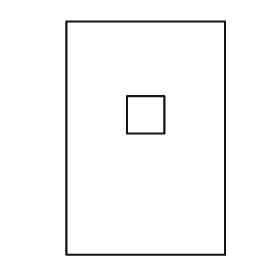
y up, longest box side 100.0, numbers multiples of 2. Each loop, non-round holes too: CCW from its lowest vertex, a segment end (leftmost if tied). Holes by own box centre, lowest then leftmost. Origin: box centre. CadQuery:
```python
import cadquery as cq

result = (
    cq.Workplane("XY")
    .moveTo(-34.0, -50.0)
    .lineTo(34.0, -50.0)
    .lineTo(34.0, 50.0)
    .lineTo(-34.0, 50.0)
    .close()
    .moveTo(-8.0, 2.0)
    .lineTo(8.0, 2.0)
    .lineTo(8.0, 18.0)
    .lineTo(-8.0, 18.0)
    .close()
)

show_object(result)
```